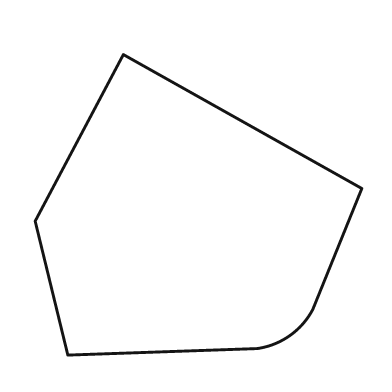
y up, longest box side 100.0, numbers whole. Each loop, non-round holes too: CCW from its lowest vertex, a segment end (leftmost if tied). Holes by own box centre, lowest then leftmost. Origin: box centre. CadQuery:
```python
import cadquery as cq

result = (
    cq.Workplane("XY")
    .moveTo(-40.0, -46.0)
    .lineTo(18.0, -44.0)
    .threePointArc((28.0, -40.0), (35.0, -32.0))
    .lineTo(50.0, 5.0)
    .lineTo(-23.0, 46.0)
    .lineTo(-50.0, -5.0)
    .close()
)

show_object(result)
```